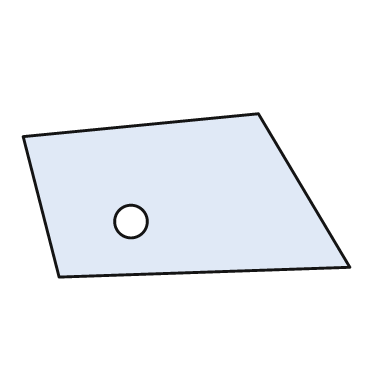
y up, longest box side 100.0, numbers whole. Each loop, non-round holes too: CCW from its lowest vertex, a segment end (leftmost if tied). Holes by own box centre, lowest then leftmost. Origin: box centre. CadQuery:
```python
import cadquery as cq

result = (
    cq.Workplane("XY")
    .moveTo(-39.0, -25.0)
    .lineTo(50.0, -22.0)
    .lineTo(22.0, 25.0)
    .lineTo(-50.0, 18.0)
    .close()
    .moveTo(-17.0, -8.0)
    .circle(5.0)
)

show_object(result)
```